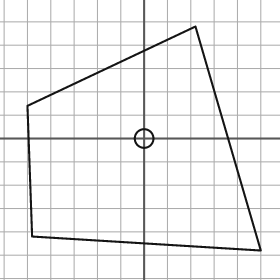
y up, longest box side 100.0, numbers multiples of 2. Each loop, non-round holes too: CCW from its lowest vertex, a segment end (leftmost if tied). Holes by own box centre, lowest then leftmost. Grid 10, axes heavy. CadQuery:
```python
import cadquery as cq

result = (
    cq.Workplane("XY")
    .moveTo(50.0, -48.0)
    .lineTo(22.0, 48.0)
    .lineTo(-50.0, 14.0)
    .lineTo(-48.0, -42.0)
    .close()
    .moveTo(0.0, 0.0)
    .circle(4.0)
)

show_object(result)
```